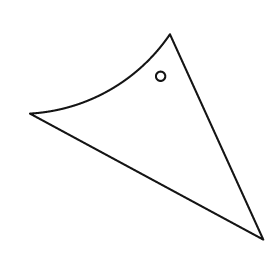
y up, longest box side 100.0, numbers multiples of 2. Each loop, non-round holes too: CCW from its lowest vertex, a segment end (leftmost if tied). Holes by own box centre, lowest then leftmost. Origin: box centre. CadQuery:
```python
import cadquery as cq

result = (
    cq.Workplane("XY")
    .moveTo(50.0, -44.0)
    .lineTo(10.0, 44.0)
    .threePointArc((-16.0, 20.0), (-50.0, 10.0))
    .close()
    .moveTo(6.0, 26.0)
    .circle(2.0)
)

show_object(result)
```